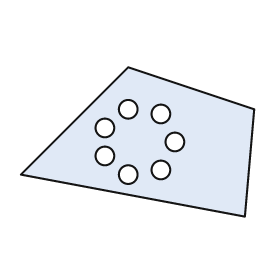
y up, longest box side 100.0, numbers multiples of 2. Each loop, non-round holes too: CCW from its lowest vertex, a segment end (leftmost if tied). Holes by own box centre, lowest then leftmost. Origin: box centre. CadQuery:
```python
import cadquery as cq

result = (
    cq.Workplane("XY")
    .moveTo(46.0, -32.0)
    .lineTo(50.0, 14.0)
    .lineTo(-4.0, 32.0)
    .lineTo(-50.0, -14.0)
    .close()
    .moveTo(-4.0, -14.0)
    .circle(4.0)
    .moveTo(10.0, -12.0)
    .circle(4.0)
    .moveTo(-14.0, -6.0)
    .circle(4.0)
    .moveTo(16.0, 0.0)
    .circle(4.0)
    .moveTo(-14.0, 6.0)
    .circle(4.0)
    .moveTo(10.0, 12.0)
    .circle(4.0)
    .moveTo(-4.0, 14.0)
    .circle(4.0)
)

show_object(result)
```